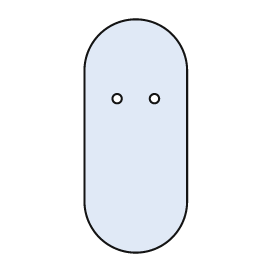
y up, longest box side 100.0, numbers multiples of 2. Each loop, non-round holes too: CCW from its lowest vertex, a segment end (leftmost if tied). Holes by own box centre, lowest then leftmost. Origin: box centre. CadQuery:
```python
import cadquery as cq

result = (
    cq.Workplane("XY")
    .moveTo(-22.0, -28.0)
    .threePointArc((0.0, -50.0), (22.0, -28.0))
    .lineTo(22.0, 28.0)
    .threePointArc((0.0, 50.0), (-22.0, 28.0))
    .close()
    .moveTo(-8.0, 16.0)
    .circle(2.0)
    .moveTo(8.0, 16.0)
    .circle(2.0)
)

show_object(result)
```